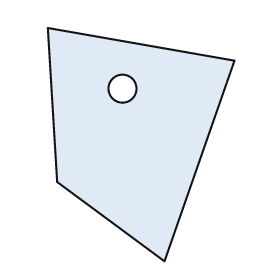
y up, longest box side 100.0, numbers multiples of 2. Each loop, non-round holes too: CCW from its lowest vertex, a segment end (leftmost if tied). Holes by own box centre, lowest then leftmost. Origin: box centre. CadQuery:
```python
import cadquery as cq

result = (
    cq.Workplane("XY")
    .moveTo(10.0, -50.0)
    .lineTo(40.0, 36.0)
    .lineTo(-40.0, 50.0)
    .lineTo(-36.0, -16.0)
    .close()
    .moveTo(-8.0, 24.0)
    .circle(6.0)
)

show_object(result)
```